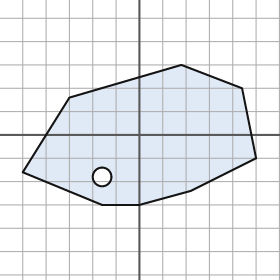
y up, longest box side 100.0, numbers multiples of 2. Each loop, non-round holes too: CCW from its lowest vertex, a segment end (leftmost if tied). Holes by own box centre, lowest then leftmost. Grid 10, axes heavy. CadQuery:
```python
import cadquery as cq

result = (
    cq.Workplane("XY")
    .moveTo(-16.0, -30.0)
    .lineTo(0.0, -30.0)
    .lineTo(22.0, -24.0)
    .lineTo(50.0, -10.0)
    .lineTo(44.0, 20.0)
    .lineTo(18.0, 30.0)
    .lineTo(-30.0, 16.0)
    .lineTo(-50.0, -16.0)
    .close()
    .moveTo(-16.0, -18.0)
    .circle(4.0)
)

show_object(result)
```